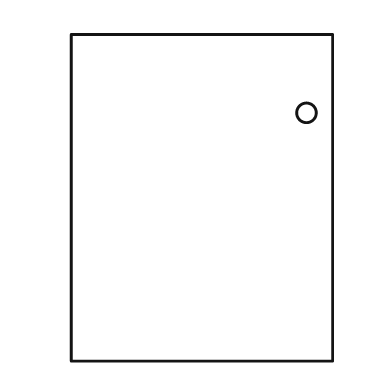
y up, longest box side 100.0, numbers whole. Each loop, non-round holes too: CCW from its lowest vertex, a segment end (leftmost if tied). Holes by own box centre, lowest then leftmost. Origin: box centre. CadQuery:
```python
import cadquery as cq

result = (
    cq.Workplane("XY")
    .moveTo(-40.0, -50.0)
    .lineTo(40.0, -50.0)
    .lineTo(40.0, 50.0)
    .lineTo(-40.0, 50.0)
    .close()
    .moveTo(32.0, 26.0)
    .circle(3.0)
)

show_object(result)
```